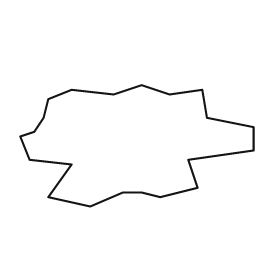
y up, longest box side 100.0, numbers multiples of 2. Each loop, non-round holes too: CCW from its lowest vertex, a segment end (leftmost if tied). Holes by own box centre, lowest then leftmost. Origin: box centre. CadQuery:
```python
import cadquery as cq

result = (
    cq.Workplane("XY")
    .moveTo(-20.0, -26.0)
    .lineTo(-6.0, -20.0)
    .lineTo(2.0, -20.0)
    .lineTo(10.0, -22.0)
    .lineTo(26.0, -18.0)
    .lineTo(22.0, -6.0)
    .lineTo(50.0, -2.0)
    .lineTo(50.0, 8.0)
    .lineTo(30.0, 12.0)
    .lineTo(28.0, 24.0)
    .lineTo(14.0, 22.0)
    .lineTo(2.0, 26.0)
    .lineTo(-10.0, 22.0)
    .lineTo(-28.0, 24.0)
    .lineTo(-38.0, 20.0)
    .lineTo(-40.0, 12.0)
    .lineTo(-44.0, 6.0)
    .lineTo(-50.0, 4.0)
    .lineTo(-46.0, -6.0)
    .lineTo(-28.0, -8.0)
    .lineTo(-38.0, -22.0)
    .close()
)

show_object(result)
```